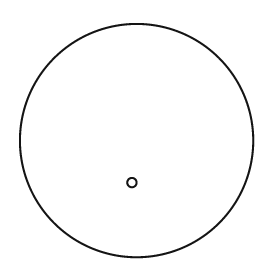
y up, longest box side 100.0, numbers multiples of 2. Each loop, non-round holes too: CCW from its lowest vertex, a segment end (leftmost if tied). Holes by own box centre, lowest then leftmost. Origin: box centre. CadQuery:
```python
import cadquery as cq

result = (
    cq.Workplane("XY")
    .moveTo(0.0, 0.0)
    .circle(50.0)
    .moveTo(-2.0, -18.0)
    .circle(2.0)
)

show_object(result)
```